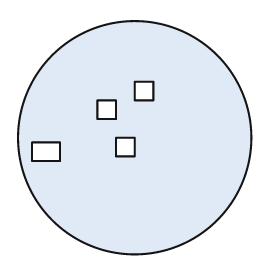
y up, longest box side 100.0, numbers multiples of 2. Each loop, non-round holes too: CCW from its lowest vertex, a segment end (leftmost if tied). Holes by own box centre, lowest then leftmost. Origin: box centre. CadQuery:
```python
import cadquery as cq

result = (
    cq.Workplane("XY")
    .moveTo(0.0, 0.0)
    .circle(50.0)
    .moveTo(-44.0, -10.0)
    .lineTo(-32.0, -10.0)
    .lineTo(-32.0, -2.0)
    .lineTo(-44.0, -2.0)
    .close()
    .moveTo(-8.0, -8.0)
    .lineTo(0.0, -8.0)
    .lineTo(0.0, 0.0)
    .lineTo(-8.0, 0.0)
    .close()
    .moveTo(-16.0, 8.0)
    .lineTo(-8.0, 8.0)
    .lineTo(-8.0, 16.0)
    .lineTo(-16.0, 16.0)
    .close()
    .moveTo(0.0, 16.0)
    .lineTo(8.0, 16.0)
    .lineTo(8.0, 24.0)
    .lineTo(0.0, 24.0)
    .close()
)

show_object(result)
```